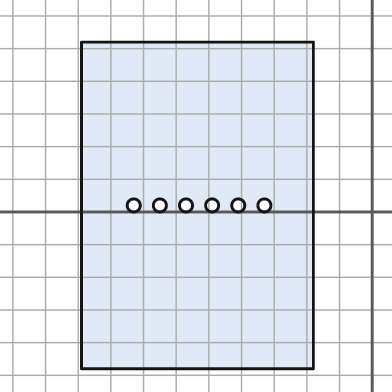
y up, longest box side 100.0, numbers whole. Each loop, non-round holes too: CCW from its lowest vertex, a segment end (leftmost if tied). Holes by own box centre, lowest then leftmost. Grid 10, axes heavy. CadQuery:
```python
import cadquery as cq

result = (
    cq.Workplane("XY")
    .moveTo(-89.0, -48.0)
    .lineTo(-18.0, -48.0)
    .lineTo(-18.0, 52.0)
    .lineTo(-89.0, 52.0)
    .close()
    .moveTo(-73.0, 2.0)
    .circle(2.0)
    .moveTo(-65.0, 2.0)
    .circle(2.0)
    .moveTo(-57.0, 2.0)
    .circle(2.0)
    .moveTo(-49.0, 2.0)
    .circle(2.0)
    .moveTo(-41.0, 2.0)
    .circle(2.0)
    .moveTo(-33.0, 2.0)
    .circle(2.0)
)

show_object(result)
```